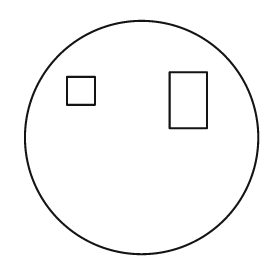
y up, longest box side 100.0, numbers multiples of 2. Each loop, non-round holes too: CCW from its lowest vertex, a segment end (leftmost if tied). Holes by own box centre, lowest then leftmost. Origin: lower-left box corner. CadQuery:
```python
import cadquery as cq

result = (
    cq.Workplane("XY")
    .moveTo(50.0, 50.0)
    .circle(50.0)
    .moveTo(62.0, 54.0)
    .lineTo(78.0, 54.0)
    .lineTo(78.0, 78.0)
    .lineTo(62.0, 78.0)
    .close()
    .moveTo(18.0, 64.0)
    .lineTo(30.0, 64.0)
    .lineTo(30.0, 76.0)
    .lineTo(18.0, 76.0)
    .close()
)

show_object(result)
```